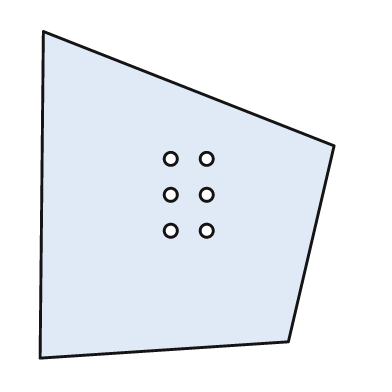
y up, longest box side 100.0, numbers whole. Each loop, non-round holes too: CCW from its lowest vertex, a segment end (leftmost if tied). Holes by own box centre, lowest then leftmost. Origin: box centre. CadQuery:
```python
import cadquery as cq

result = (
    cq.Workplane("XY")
    .moveTo(-45.0, -50.0)
    .lineTo(31.0, -45.0)
    .lineTo(45.0, 15.0)
    .lineTo(-44.0, 50.0)
    .close()
    .moveTo(-5.0, -11.0)
    .circle(2.0)
    .moveTo(6.0, -11.0)
    .circle(2.0)
    .moveTo(-5.0, 0.0)
    .circle(2.0)
    .moveTo(6.0, 0.0)
    .circle(2.0)
    .moveTo(-5.0, 11.0)
    .circle(2.0)
    .moveTo(6.0, 11.0)
    .circle(2.0)
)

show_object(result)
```